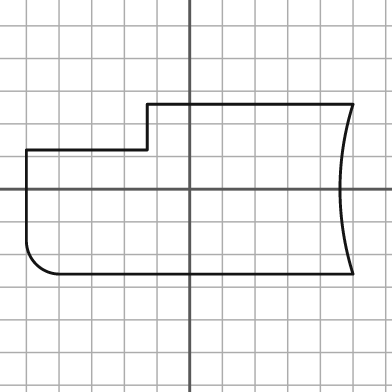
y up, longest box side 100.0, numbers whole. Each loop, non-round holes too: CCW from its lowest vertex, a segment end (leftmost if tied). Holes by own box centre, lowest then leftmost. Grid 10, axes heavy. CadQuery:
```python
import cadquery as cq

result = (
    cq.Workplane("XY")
    .moveTo(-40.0, -26.0)
    .lineTo(50.0, -26.0)
    .threePointArc((46.0, 0.0), (50.0, 26.0))
    .lineTo(-13.0, 26.0)
    .lineTo(-13.0, 12.0)
    .lineTo(-50.0, 12.0)
    .lineTo(-50.0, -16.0)
    .threePointArc((-47.0, -23.0), (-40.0, -26.0))
    .close()
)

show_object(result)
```